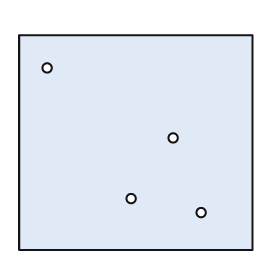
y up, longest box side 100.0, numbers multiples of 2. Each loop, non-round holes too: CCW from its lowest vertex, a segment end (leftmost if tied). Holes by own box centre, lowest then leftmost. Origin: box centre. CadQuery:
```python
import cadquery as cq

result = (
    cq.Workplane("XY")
    .moveTo(-50.0, -46.0)
    .lineTo(50.0, -46.0)
    .lineTo(50.0, 46.0)
    .lineTo(-50.0, 46.0)
    .close()
    .moveTo(28.0, -30.0)
    .circle(2.0)
    .moveTo(-2.0, -24.0)
    .circle(2.0)
    .moveTo(16.0, 2.0)
    .circle(2.0)
    .moveTo(-38.0, 32.0)
    .circle(2.0)
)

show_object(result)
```